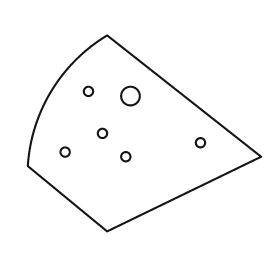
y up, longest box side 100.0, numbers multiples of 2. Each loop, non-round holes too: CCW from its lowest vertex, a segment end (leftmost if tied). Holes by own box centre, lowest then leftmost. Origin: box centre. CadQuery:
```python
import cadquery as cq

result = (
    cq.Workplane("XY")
    .moveTo(-16.0, -42.0)
    .lineTo(50.0, -10.0)
    .lineTo(-16.0, 42.0)
    .threePointArc((-40.0, 18.0), (-50.0, -14.0))
    .close()
    .moveTo(-8.0, -10.0)
    .circle(2.0)
    .moveTo(-34.0, -8.0)
    .circle(2.0)
    .moveTo(24.0, -4.0)
    .circle(2.0)
    .moveTo(-18.0, 0.0)
    .circle(2.0)
    .moveTo(-6.0, 16.0)
    .circle(4.0)
    .moveTo(-24.0, 18.0)
    .circle(2.0)
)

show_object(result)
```